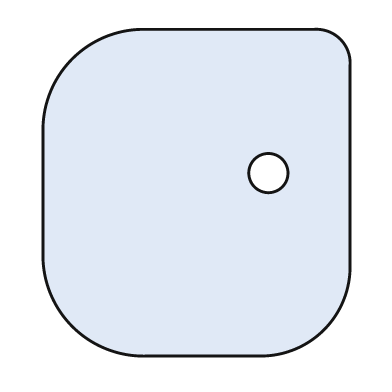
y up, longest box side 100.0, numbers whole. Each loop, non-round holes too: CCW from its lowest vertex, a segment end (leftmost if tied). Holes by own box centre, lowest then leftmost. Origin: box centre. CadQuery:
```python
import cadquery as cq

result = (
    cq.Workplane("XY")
    .moveTo(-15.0, -50.0)
    .lineTo(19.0, -50.0)
    .threePointArc((39.0, -42.0), (47.0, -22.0))
    .lineTo(47.0, 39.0)
    .threePointArc((44.0, 47.0), (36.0, 50.0))
    .lineTo(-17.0, 50.0)
    .threePointArc((-38.0, 41.0), (-47.0, 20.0))
    .lineTo(-47.0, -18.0)
    .threePointArc((-38.0, -41.0), (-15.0, -50.0))
    .close()
    .moveTo(22.0, 6.0)
    .circle(6.0)
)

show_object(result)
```